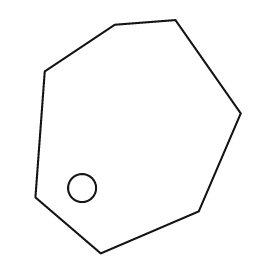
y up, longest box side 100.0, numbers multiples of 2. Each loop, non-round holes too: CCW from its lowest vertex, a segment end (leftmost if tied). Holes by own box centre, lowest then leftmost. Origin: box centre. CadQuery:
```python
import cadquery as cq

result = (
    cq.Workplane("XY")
    .moveTo(-16.0, -50.0)
    .lineTo(26.0, -32.0)
    .lineTo(44.0, 10.0)
    .lineTo(16.0, 50.0)
    .lineTo(-10.0, 48.0)
    .lineTo(-40.0, 28.0)
    .lineTo(-44.0, -26.0)
    .close()
    .moveTo(-24.0, -22.0)
    .circle(6.0)
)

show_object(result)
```